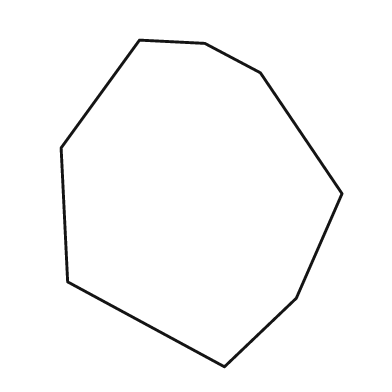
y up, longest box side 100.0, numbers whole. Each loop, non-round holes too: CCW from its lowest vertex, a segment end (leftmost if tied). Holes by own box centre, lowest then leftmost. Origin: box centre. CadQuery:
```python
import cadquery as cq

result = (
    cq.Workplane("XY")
    .moveTo(7.0, -50.0)
    .lineTo(29.0, -29.0)
    .lineTo(43.0, 3.0)
    .lineTo(18.0, 40.0)
    .lineTo(1.0, 49.0)
    .lineTo(-19.0, 50.0)
    .lineTo(-43.0, 17.0)
    .lineTo(-41.0, -24.0)
    .close()
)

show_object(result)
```